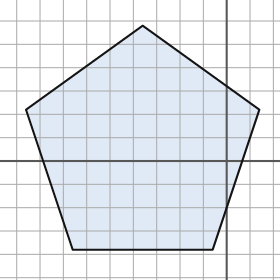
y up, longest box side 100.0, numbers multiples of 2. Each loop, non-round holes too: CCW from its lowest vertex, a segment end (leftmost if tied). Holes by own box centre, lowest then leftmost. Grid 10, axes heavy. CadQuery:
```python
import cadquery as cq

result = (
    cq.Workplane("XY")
    .moveTo(-66.0, -38.0)
    .lineTo(-6.0, -38.0)
    .lineTo(14.0, 22.0)
    .lineTo(-36.0, 58.0)
    .lineTo(-86.0, 22.0)
    .close()
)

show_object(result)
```